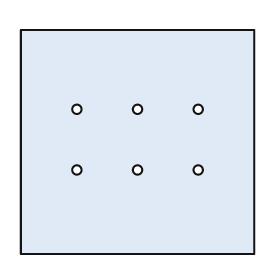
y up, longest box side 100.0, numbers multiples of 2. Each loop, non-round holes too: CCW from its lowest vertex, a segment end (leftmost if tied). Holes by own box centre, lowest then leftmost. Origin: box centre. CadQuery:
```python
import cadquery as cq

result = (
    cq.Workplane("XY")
    .moveTo(-50.0, -48.0)
    .lineTo(50.0, -48.0)
    .lineTo(50.0, 48.0)
    .lineTo(-50.0, 48.0)
    .close()
    .moveTo(-26.0, -12.0)
    .circle(2.0)
    .moveTo(0.0, -12.0)
    .circle(2.0)
    .moveTo(26.0, -12.0)
    .circle(2.0)
    .moveTo(-26.0, 14.0)
    .circle(2.0)
    .moveTo(0.0, 14.0)
    .circle(2.0)
    .moveTo(26.0, 14.0)
    .circle(2.0)
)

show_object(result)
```